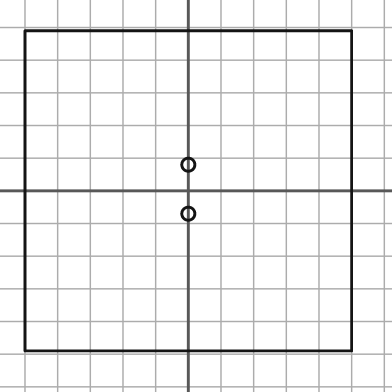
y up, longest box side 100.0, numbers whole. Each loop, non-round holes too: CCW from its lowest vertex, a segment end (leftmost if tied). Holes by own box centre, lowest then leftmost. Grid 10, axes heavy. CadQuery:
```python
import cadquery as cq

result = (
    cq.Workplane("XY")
    .moveTo(-50.0, -49.0)
    .lineTo(50.0, -49.0)
    .lineTo(50.0, 49.0)
    .lineTo(-50.0, 49.0)
    .close()
    .moveTo(0.0, -7.0)
    .circle(2.0)
    .moveTo(0.0, 8.0)
    .circle(2.0)
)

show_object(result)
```